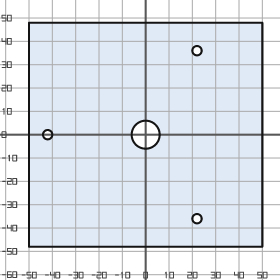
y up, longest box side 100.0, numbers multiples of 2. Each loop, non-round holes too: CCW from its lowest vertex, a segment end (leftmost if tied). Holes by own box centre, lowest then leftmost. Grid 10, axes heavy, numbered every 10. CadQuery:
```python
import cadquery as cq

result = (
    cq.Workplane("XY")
    .moveTo(-50.0, -48.0)
    .lineTo(50.0, -48.0)
    .lineTo(50.0, 48.0)
    .lineTo(-50.0, 48.0)
    .close()
    .moveTo(22.0, -36.0)
    .circle(2.0)
    .moveTo(-42.0, 0.0)
    .circle(2.0)
    .moveTo(0.0, 0.0)
    .circle(6.0)
    .moveTo(22.0, 36.0)
    .circle(2.0)
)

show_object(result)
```